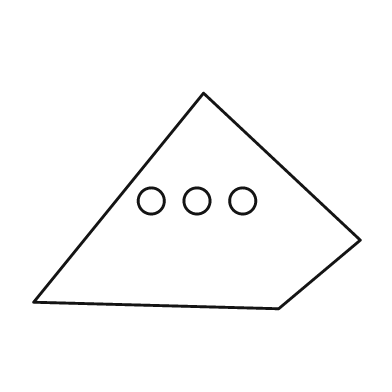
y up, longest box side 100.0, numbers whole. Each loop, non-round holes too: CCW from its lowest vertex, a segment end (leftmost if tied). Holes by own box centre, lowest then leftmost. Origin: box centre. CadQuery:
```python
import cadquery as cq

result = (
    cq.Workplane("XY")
    .moveTo(25.0, -33.0)
    .lineTo(50.0, -12.0)
    .lineTo(2.0, 33.0)
    .lineTo(-50.0, -31.0)
    .close()
    .moveTo(-14.0, 0.0)
    .circle(4.0)
    .moveTo(0.0, 0.0)
    .circle(4.0)
    .moveTo(14.0, 0.0)
    .circle(4.0)
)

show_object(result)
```